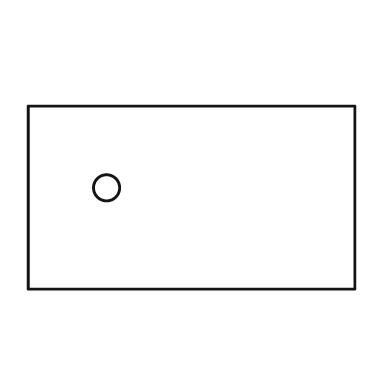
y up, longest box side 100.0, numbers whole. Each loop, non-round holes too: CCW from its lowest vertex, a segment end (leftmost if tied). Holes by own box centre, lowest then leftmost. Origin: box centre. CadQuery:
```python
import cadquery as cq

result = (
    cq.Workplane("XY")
    .moveTo(-50.0, -28.0)
    .lineTo(50.0, -28.0)
    .lineTo(50.0, 28.0)
    .lineTo(-50.0, 28.0)
    .close()
    .moveTo(-26.0, 3.0)
    .circle(4.0)
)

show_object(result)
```